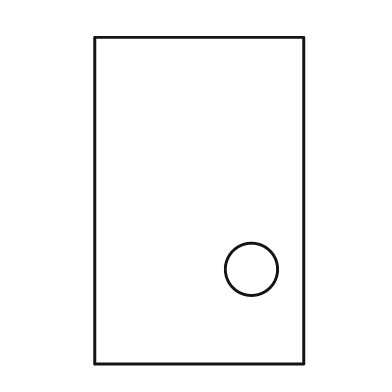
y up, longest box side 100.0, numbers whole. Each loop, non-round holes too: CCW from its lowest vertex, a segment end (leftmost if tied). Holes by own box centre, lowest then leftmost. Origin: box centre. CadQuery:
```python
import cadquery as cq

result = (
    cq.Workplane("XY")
    .moveTo(-32.0, -50.0)
    .lineTo(32.0, -50.0)
    .lineTo(32.0, 50.0)
    .lineTo(-32.0, 50.0)
    .close()
    .moveTo(16.0, -21.0)
    .circle(8.0)
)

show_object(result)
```